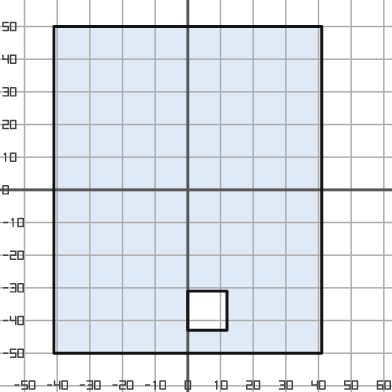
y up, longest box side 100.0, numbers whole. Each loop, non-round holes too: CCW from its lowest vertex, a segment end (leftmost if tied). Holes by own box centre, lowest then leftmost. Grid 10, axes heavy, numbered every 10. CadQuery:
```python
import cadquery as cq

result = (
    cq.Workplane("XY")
    .moveTo(-41.0, -50.0)
    .lineTo(41.0, -50.0)
    .lineTo(41.0, 50.0)
    .lineTo(-41.0, 50.0)
    .close()
    .moveTo(0.0, -43.0)
    .lineTo(12.0, -43.0)
    .lineTo(12.0, -31.0)
    .lineTo(0.0, -31.0)
    .close()
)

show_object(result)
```